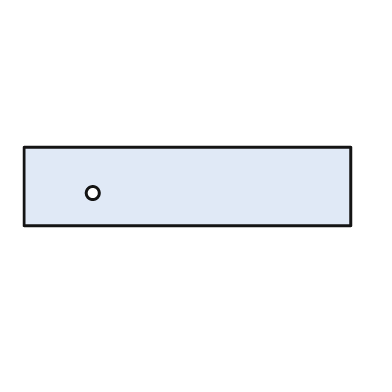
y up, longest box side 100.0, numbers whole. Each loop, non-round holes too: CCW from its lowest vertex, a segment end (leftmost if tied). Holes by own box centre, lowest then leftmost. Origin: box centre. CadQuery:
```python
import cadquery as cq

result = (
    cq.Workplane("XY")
    .moveTo(-50.0, -12.0)
    .lineTo(50.0, -12.0)
    .lineTo(50.0, 12.0)
    .lineTo(-50.0, 12.0)
    .close()
    .moveTo(-29.0, -2.0)
    .circle(2.0)
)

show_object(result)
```